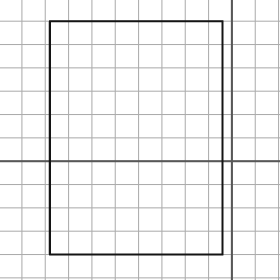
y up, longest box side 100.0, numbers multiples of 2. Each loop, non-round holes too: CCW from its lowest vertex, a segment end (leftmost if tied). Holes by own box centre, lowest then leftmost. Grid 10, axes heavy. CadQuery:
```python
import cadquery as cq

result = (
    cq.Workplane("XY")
    .moveTo(-78.0, -40.0)
    .lineTo(-4.0, -40.0)
    .lineTo(-4.0, 60.0)
    .lineTo(-78.0, 60.0)
    .close()
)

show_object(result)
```